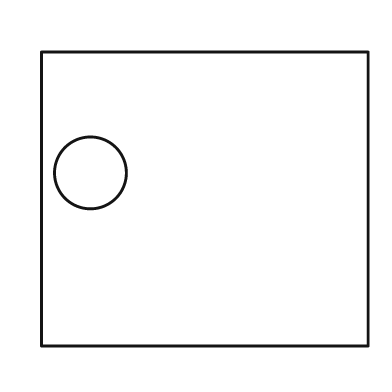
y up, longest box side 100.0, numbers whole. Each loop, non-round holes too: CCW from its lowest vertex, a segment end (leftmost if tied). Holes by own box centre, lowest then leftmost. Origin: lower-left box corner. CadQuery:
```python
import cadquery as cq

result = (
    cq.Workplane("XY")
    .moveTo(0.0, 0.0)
    .lineTo(100.0, 0.0)
    .lineTo(100.0, 90.0)
    .lineTo(0.0, 90.0)
    .close()
    .moveTo(15.0, 53.0)
    .circle(11.0)
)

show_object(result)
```